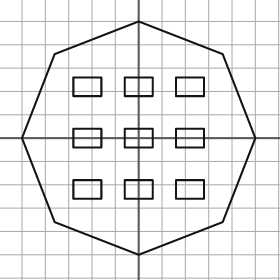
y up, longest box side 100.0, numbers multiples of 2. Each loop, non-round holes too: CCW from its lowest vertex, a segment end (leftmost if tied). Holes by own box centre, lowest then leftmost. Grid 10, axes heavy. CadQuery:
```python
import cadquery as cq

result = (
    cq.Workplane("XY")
    .moveTo(0.0, -50.0)
    .lineTo(36.0, -36.0)
    .lineTo(50.0, 0.0)
    .lineTo(36.0, 36.0)
    .lineTo(0.0, 50.0)
    .lineTo(-36.0, 36.0)
    .lineTo(-50.0, 0.0)
    .lineTo(-36.0, -36.0)
    .close()
    .moveTo(-28.0, -26.0)
    .lineTo(-16.0, -26.0)
    .lineTo(-16.0, -18.0)
    .lineTo(-28.0, -18.0)
    .close()
    .moveTo(-6.0, -26.0)
    .lineTo(6.0, -26.0)
    .lineTo(6.0, -18.0)
    .lineTo(-6.0, -18.0)
    .close()
    .moveTo(16.0, -26.0)
    .lineTo(28.0, -26.0)
    .lineTo(28.0, -18.0)
    .lineTo(16.0, -18.0)
    .close()
    .moveTo(-28.0, -4.0)
    .lineTo(-16.0, -4.0)
    .lineTo(-16.0, 4.0)
    .lineTo(-28.0, 4.0)
    .close()
    .moveTo(-6.0, -4.0)
    .lineTo(6.0, -4.0)
    .lineTo(6.0, 4.0)
    .lineTo(-6.0, 4.0)
    .close()
    .moveTo(16.0, -4.0)
    .lineTo(28.0, -4.0)
    .lineTo(28.0, 4.0)
    .lineTo(16.0, 4.0)
    .close()
    .moveTo(-28.0, 18.0)
    .lineTo(-16.0, 18.0)
    .lineTo(-16.0, 26.0)
    .lineTo(-28.0, 26.0)
    .close()
    .moveTo(-6.0, 18.0)
    .lineTo(6.0, 18.0)
    .lineTo(6.0, 26.0)
    .lineTo(-6.0, 26.0)
    .close()
    .moveTo(16.0, 18.0)
    .lineTo(28.0, 18.0)
    .lineTo(28.0, 26.0)
    .lineTo(16.0, 26.0)
    .close()
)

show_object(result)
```